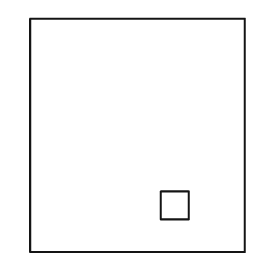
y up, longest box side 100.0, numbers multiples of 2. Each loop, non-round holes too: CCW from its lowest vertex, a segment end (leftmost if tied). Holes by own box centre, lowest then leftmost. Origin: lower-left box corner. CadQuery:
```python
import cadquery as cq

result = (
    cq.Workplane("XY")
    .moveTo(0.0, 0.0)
    .lineTo(92.0, 0.0)
    .lineTo(92.0, 100.0)
    .lineTo(0.0, 100.0)
    .close()
    .moveTo(56.0, 14.0)
    .lineTo(68.0, 14.0)
    .lineTo(68.0, 26.0)
    .lineTo(56.0, 26.0)
    .close()
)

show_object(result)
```